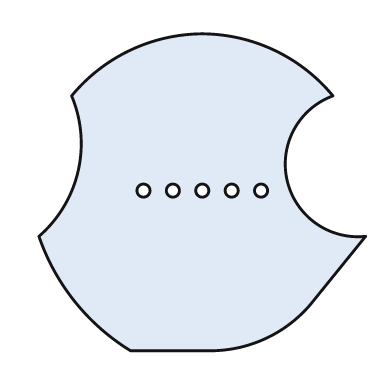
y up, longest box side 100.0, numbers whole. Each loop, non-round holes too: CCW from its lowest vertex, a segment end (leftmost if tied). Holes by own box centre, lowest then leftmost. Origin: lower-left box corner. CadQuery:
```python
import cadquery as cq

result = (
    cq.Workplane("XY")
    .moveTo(28.0, 0.0)
    .lineTo(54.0, 0.0)
    .threePointArc((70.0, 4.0), (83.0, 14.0))
    .lineTo(100.0, 35.0)
    .threePointArc((76.0, 52.0), (90.0, 78.0))
    .threePointArc((72.0, 92.0), (50.0, 97.0))
    .threePointArc((28.0, 92.0), (10.0, 78.0))
    .threePointArc((12.0, 55.0), (0.0, 35.0))
    .threePointArc((11.0, 15.0), (28.0, 0.0))
    .close()
    .moveTo(32.0, 49.0)
    .circle(2.0)
    .moveTo(41.0, 49.0)
    .circle(2.0)
    .moveTo(50.0, 49.0)
    .circle(2.0)
    .moveTo(59.0, 49.0)
    .circle(2.0)
    .moveTo(68.0, 49.0)
    .circle(2.0)
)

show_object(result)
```